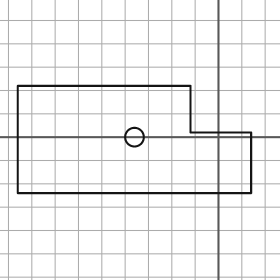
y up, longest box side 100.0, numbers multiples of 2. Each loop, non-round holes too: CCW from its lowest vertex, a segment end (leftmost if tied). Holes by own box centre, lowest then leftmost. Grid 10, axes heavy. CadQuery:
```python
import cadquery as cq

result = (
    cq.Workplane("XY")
    .moveTo(-86.0, -24.0)
    .lineTo(14.0, -24.0)
    .lineTo(14.0, 2.0)
    .lineTo(-12.0, 2.0)
    .lineTo(-12.0, 22.0)
    .lineTo(-86.0, 22.0)
    .close()
    .moveTo(-36.0, 0.0)
    .circle(4.0)
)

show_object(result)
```